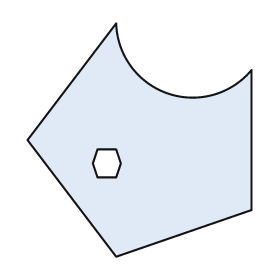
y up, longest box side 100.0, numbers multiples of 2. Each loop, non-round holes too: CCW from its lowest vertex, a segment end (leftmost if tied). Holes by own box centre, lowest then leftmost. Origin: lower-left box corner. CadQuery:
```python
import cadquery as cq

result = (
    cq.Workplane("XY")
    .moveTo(38.0, 0.0)
    .lineTo(96.0, 20.0)
    .lineTo(96.0, 80.0)
    .threePointArc((60.0, 70.0), (38.0, 100.0))
    .lineTo(0.0, 50.0)
    .close()
    .moveTo(30.0, 34.0)
    .lineTo(38.0, 34.0)
    .lineTo(40.0, 40.0)
    .lineTo(38.0, 46.0)
    .lineTo(30.0, 46.0)
    .lineTo(28.0, 40.0)
    .close()
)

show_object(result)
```